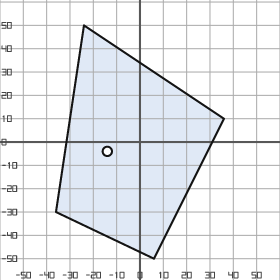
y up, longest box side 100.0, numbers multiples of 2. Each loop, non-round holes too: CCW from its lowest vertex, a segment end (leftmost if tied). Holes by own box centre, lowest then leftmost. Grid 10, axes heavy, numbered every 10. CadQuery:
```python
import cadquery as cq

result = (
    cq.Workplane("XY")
    .moveTo(6.0, -50.0)
    .lineTo(36.0, 10.0)
    .lineTo(-24.0, 50.0)
    .lineTo(-36.0, -30.0)
    .close()
    .moveTo(-14.0, -4.0)
    .circle(2.0)
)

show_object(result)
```